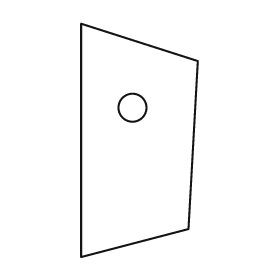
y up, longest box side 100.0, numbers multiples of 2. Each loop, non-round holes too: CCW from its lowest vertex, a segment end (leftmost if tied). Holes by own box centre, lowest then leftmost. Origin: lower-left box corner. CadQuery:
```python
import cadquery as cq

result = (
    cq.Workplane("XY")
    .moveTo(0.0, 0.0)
    .lineTo(46.0, 12.0)
    .lineTo(50.0, 84.0)
    .lineTo(0.0, 100.0)
    .close()
    .moveTo(22.0, 64.0)
    .circle(6.0)
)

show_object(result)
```